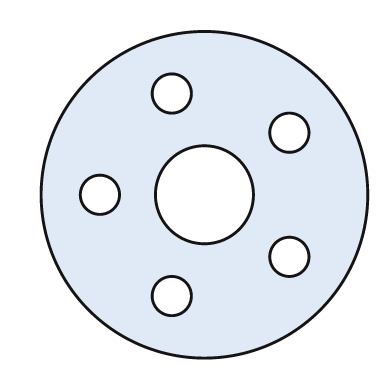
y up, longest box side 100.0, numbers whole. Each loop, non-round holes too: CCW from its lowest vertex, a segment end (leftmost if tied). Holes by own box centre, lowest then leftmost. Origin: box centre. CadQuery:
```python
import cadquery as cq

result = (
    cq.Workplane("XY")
    .moveTo(0.0, 0.0)
    .circle(50.0)
    .moveTo(-10.0, -31.0)
    .circle(6.0)
    .moveTo(26.0, -19.0)
    .circle(6.0)
    .moveTo(-32.0, 0.0)
    .circle(6.0)
    .moveTo(0.0, 0.0)
    .circle(15.0)
    .moveTo(26.0, 19.0)
    .circle(6.0)
    .moveTo(-10.0, 31.0)
    .circle(6.0)
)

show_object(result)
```